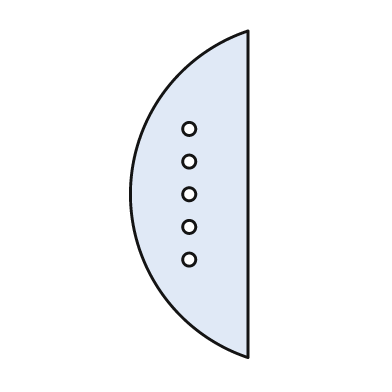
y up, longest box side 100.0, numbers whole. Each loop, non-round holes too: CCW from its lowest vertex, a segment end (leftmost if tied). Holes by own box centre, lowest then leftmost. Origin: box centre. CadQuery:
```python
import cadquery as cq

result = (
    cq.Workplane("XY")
    .moveTo(18.0, -50.0)
    .lineTo(18.0, 50.0)
    .threePointArc((-18.0, 0.0), (18.0, -50.0))
    .close()
    .moveTo(0.0, -20.0)
    .circle(2.0)
    .moveTo(0.0, -10.0)
    .circle(2.0)
    .moveTo(0.0, 0.0)
    .circle(2.0)
    .moveTo(0.0, 10.0)
    .circle(2.0)
    .moveTo(0.0, 20.0)
    .circle(2.0)
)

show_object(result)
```